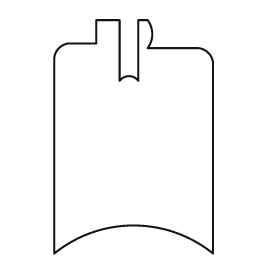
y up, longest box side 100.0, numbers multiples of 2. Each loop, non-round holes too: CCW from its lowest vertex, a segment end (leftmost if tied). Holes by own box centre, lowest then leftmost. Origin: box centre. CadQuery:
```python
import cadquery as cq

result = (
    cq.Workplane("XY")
    .moveTo(-34.0, -50.0)
    .threePointArc((0.0, -38.0), (34.0, -50.0))
    .lineTo(34.0, 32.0)
    .threePointArc((32.0, 36.0), (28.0, 38.0))
    .lineTo(6.0, 38.0)
    .threePointArc((8.0, 44.0), (6.0, 50.0))
    .lineTo(2.0, 50.0)
    .lineTo(2.0, 24.0)
    .threePointArc((-2.0, 26.0), (-6.0, 24.0))
    .lineTo(-6.0, 50.0)
    .lineTo(-16.0, 50.0)
    .lineTo(-16.0, 40.0)
    .lineTo(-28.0, 40.0)
    .threePointArc((-32.0, 38.0), (-34.0, 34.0))
    .close()
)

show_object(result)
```